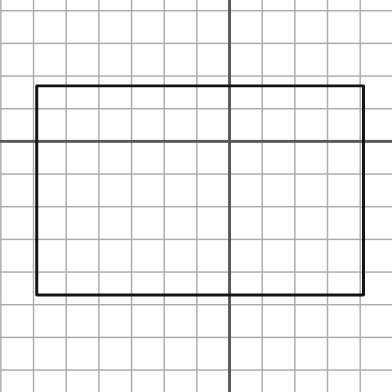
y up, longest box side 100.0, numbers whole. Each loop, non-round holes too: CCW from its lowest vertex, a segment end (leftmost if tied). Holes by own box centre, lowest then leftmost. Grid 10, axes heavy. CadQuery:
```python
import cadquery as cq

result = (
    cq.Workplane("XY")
    .moveTo(-59.0, -47.0)
    .lineTo(41.0, -47.0)
    .lineTo(41.0, 17.0)
    .lineTo(-59.0, 17.0)
    .close()
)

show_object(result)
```